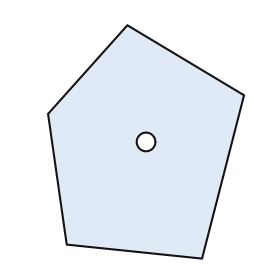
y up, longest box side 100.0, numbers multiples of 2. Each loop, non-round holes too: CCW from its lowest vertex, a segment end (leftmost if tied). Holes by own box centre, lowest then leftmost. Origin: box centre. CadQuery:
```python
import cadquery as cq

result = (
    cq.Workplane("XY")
    .moveTo(24.0, -50.0)
    .lineTo(42.0, 20.0)
    .lineTo(-8.0, 50.0)
    .lineTo(-42.0, 12.0)
    .lineTo(-34.0, -44.0)
    .close()
    .moveTo(0.0, 0.0)
    .circle(4.0)
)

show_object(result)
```